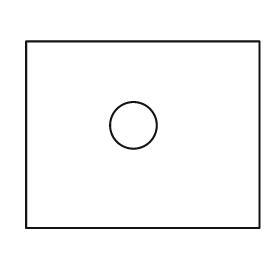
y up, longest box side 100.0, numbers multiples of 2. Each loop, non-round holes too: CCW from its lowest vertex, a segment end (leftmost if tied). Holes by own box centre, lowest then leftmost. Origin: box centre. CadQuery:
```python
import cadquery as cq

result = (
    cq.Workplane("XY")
    .moveTo(-50.0, -40.0)
    .lineTo(50.0, -40.0)
    .lineTo(50.0, 40.0)
    .lineTo(-50.0, 40.0)
    .close()
    .moveTo(-4.0, 4.0)
    .circle(10.0)
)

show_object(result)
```